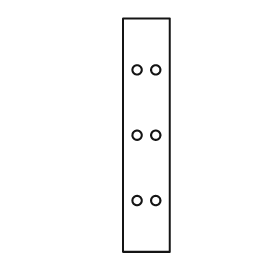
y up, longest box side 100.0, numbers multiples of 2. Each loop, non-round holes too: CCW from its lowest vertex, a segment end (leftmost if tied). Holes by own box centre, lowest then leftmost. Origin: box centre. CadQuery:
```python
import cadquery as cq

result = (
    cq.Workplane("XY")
    .moveTo(-10.0, -50.0)
    .lineTo(10.0, -50.0)
    .lineTo(10.0, 50.0)
    .lineTo(-10.0, 50.0)
    .close()
    .moveTo(-4.0, -28.0)
    .circle(2.0)
    .moveTo(4.0, -28.0)
    .circle(2.0)
    .moveTo(-4.0, 0.0)
    .circle(2.0)
    .moveTo(4.0, 0.0)
    .circle(2.0)
    .moveTo(-4.0, 28.0)
    .circle(2.0)
    .moveTo(4.0, 28.0)
    .circle(2.0)
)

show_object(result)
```